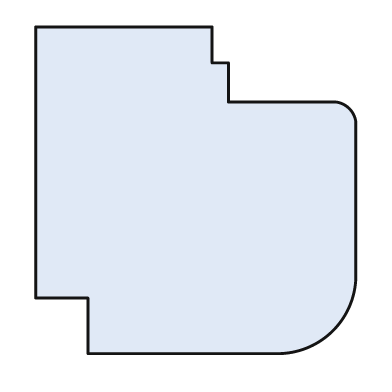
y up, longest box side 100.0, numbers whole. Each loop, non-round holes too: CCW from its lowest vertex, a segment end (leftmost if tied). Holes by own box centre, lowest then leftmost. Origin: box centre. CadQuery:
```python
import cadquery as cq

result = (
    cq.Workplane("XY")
    .moveTo(-33.0, -50.0)
    .lineTo(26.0, -50.0)
    .threePointArc((42.0, -43.0), (49.0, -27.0))
    .lineTo(49.0, 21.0)
    .threePointArc((47.0, 25.0), (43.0, 27.0))
    .lineTo(10.0, 27.0)
    .lineTo(10.0, 39.0)
    .lineTo(5.0, 39.0)
    .lineTo(5.0, 50.0)
    .lineTo(-49.0, 50.0)
    .lineTo(-49.0, -33.0)
    .lineTo(-33.0, -33.0)
    .close()
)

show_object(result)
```